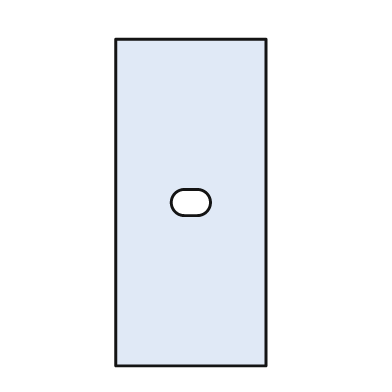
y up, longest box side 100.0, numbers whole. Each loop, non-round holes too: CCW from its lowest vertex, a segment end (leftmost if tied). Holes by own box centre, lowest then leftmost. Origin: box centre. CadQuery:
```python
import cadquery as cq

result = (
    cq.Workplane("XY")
    .moveTo(-23.0, -50.0)
    .lineTo(23.0, -50.0)
    .lineTo(23.0, 50.0)
    .lineTo(-23.0, 50.0)
    .close()
    .moveTo(-2.0, -4.0)
    .lineTo(2.0, -4.0)
    .threePointArc((6.0, 0.0), (2.0, 4.0))
    .lineTo(-2.0, 4.0)
    .threePointArc((-6.0, 0.0), (-2.0, -4.0))
    .close()
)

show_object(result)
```